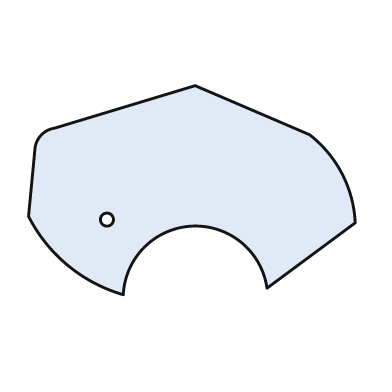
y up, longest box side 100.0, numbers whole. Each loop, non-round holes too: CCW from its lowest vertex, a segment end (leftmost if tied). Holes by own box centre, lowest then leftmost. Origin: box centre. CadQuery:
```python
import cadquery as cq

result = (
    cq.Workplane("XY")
    .moveTo(-21.0, -32.0)
    .threePointArc((0.0, -11.0), (23.0, -30.0))
    .lineTo(50.0, -10.0)
    .threePointArc((46.0, 5.0), (36.0, 17.0))
    .lineTo(1.0, 32.0)
    .lineTo(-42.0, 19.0)
    .threePointArc((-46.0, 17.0), (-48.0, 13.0))
    .lineTo(-50.0, -8.0)
    .threePointArc((-38.0, -23.0), (-21.0, -32.0))
    .close()
    .moveTo(-26.0, -9.0)
    .circle(2.0)
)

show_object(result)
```